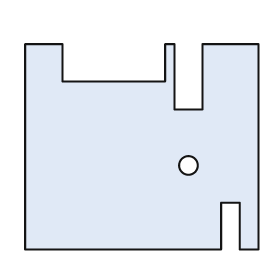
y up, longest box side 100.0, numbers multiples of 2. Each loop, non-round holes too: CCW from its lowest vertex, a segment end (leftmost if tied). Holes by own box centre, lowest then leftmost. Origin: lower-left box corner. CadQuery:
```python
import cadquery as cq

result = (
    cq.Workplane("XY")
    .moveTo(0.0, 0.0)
    .lineTo(84.0, 0.0)
    .lineTo(84.0, 20.0)
    .lineTo(92.0, 20.0)
    .lineTo(92.0, 0.0)
    .lineTo(100.0, 0.0)
    .lineTo(100.0, 88.0)
    .lineTo(76.0, 88.0)
    .lineTo(76.0, 60.0)
    .lineTo(64.0, 60.0)
    .lineTo(64.0, 88.0)
    .lineTo(60.0, 88.0)
    .lineTo(60.0, 72.0)
    .lineTo(16.0, 72.0)
    .lineTo(16.0, 88.0)
    .lineTo(0.0, 88.0)
    .close()
    .moveTo(70.0, 36.0)
    .circle(4.0)
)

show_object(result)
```